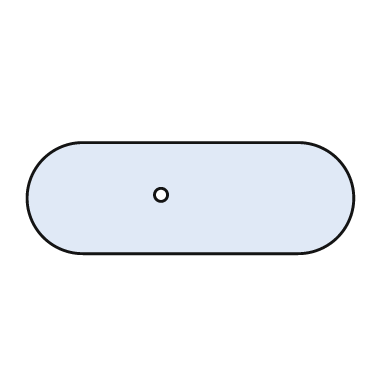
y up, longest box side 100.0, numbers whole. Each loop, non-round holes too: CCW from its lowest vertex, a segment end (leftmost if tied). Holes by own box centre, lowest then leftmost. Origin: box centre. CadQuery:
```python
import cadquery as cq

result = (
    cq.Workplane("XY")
    .moveTo(-33.0, -17.0)
    .lineTo(33.0, -17.0)
    .threePointArc((50.0, 0.0), (33.0, 17.0))
    .lineTo(-33.0, 17.0)
    .threePointArc((-50.0, 0.0), (-33.0, -17.0))
    .close()
    .moveTo(-9.0, 1.0)
    .circle(2.0)
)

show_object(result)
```